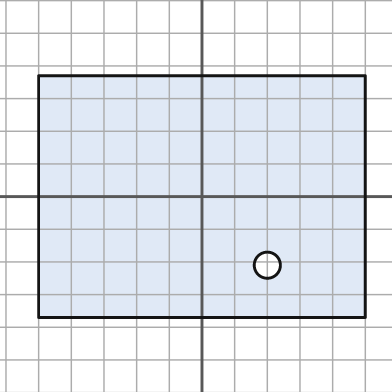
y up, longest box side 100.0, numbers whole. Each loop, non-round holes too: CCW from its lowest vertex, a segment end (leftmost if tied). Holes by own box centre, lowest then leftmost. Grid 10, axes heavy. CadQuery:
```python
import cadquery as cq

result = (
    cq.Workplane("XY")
    .moveTo(-50.0, -37.0)
    .lineTo(50.0, -37.0)
    .lineTo(50.0, 37.0)
    .lineTo(-50.0, 37.0)
    .close()
    .moveTo(20.0, -21.0)
    .circle(4.0)
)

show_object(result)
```